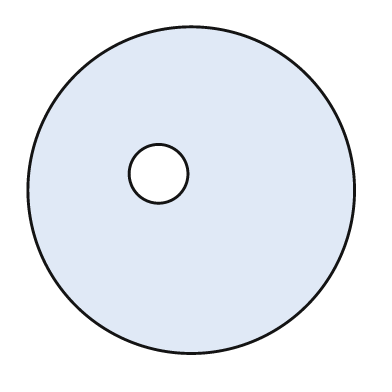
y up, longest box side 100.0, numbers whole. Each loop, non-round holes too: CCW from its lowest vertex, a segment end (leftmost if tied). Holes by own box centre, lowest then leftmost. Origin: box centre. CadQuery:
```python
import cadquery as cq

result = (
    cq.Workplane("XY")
    .moveTo(0.0, 0.0)
    .circle(50.0)
    .moveTo(-10.0, 5.0)
    .circle(9.0)
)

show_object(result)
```